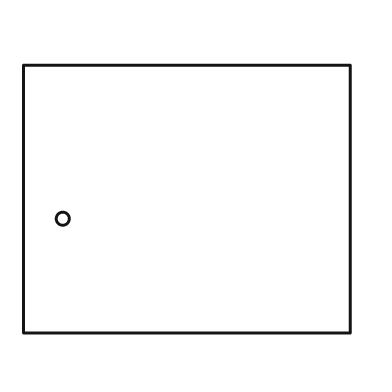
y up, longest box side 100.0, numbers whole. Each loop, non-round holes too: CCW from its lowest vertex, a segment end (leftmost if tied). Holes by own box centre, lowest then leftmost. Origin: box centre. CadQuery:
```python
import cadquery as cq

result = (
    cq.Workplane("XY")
    .moveTo(-50.0, -41.0)
    .lineTo(50.0, -41.0)
    .lineTo(50.0, 41.0)
    .lineTo(-50.0, 41.0)
    .close()
    .moveTo(-38.0, -6.0)
    .circle(2.0)
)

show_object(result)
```